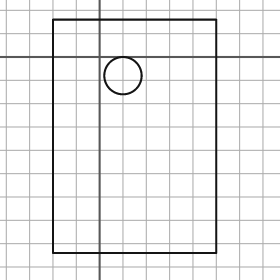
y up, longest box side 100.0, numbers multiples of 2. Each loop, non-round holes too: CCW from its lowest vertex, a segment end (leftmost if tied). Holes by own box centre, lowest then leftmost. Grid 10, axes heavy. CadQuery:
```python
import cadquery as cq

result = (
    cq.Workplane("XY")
    .moveTo(-20.0, -84.0)
    .lineTo(50.0, -84.0)
    .lineTo(50.0, 16.0)
    .lineTo(-20.0, 16.0)
    .close()
    .moveTo(10.0, -8.0)
    .circle(8.0)
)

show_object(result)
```